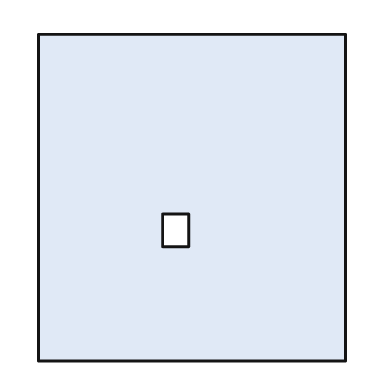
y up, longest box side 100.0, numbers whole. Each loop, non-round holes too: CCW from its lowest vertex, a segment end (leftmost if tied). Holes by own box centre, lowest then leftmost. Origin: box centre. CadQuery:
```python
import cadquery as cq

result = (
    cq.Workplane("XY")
    .moveTo(-47.0, -50.0)
    .lineTo(47.0, -50.0)
    .lineTo(47.0, 50.0)
    .lineTo(-47.0, 50.0)
    .close()
    .moveTo(-9.0, -15.0)
    .lineTo(-1.0, -15.0)
    .lineTo(-1.0, -5.0)
    .lineTo(-9.0, -5.0)
    .close()
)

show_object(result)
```